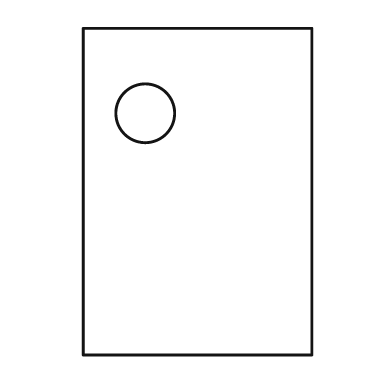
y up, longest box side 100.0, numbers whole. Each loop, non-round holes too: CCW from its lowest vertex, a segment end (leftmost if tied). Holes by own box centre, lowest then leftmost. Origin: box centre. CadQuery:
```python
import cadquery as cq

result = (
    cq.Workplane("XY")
    .moveTo(-35.0, -50.0)
    .lineTo(35.0, -50.0)
    .lineTo(35.0, 50.0)
    .lineTo(-35.0, 50.0)
    .close()
    .moveTo(-16.0, 24.0)
    .circle(9.0)
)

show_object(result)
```